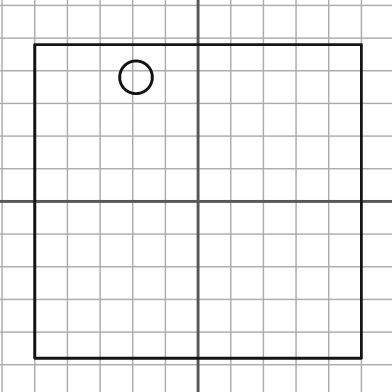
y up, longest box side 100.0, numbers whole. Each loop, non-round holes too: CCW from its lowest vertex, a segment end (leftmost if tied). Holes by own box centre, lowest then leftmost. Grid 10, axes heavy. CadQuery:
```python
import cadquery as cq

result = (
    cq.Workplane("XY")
    .moveTo(-50.0, -48.0)
    .lineTo(50.0, -48.0)
    .lineTo(50.0, 48.0)
    .lineTo(-50.0, 48.0)
    .close()
    .moveTo(-19.0, 38.0)
    .circle(5.0)
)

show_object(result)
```